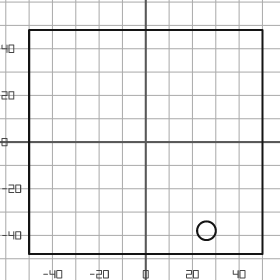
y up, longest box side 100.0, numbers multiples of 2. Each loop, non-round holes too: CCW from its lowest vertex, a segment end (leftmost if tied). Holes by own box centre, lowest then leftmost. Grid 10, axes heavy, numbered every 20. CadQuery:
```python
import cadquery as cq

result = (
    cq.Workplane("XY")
    .moveTo(-50.0, -48.0)
    .lineTo(50.0, -48.0)
    .lineTo(50.0, 48.0)
    .lineTo(-50.0, 48.0)
    .close()
    .moveTo(26.0, -38.0)
    .circle(4.0)
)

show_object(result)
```